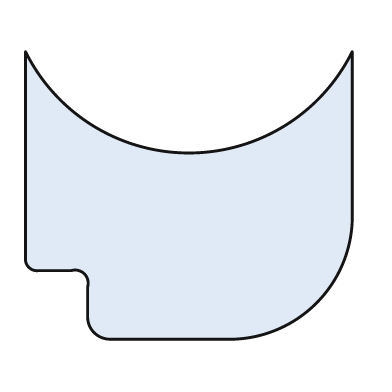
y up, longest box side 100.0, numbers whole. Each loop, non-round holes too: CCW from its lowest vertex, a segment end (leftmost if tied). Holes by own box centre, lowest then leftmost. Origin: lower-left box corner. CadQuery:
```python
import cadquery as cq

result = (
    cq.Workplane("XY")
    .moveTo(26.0, 0.0)
    .lineTo(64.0, 0.0)
    .threePointArc((89.0, 11.0), (100.0, 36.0))
    .lineTo(100.0, 88.0)
    .threePointArc((50.0, 57.0), (0.0, 88.0))
    .lineTo(0.0, 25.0)
    .threePointArc((1.0, 22.0), (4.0, 21.0))
    .lineTo(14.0, 21.0)
    .threePointArc((18.0, 20.0), (19.0, 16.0))
    .lineTo(19.0, 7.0)
    .threePointArc((21.0, 2.0), (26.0, 0.0))
    .close()
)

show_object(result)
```